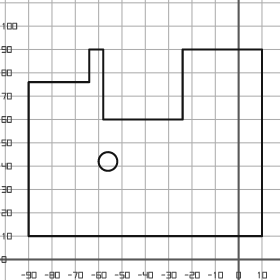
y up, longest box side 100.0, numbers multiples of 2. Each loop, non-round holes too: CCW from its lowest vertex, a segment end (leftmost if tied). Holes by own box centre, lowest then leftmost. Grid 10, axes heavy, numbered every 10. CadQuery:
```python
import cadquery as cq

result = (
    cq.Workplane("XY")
    .moveTo(-90.0, 10.0)
    .lineTo(10.0, 10.0)
    .lineTo(10.0, 90.0)
    .lineTo(-24.0, 90.0)
    .lineTo(-24.0, 60.0)
    .lineTo(-58.0, 60.0)
    .lineTo(-58.0, 90.0)
    .lineTo(-64.0, 90.0)
    .lineTo(-64.0, 76.0)
    .lineTo(-90.0, 76.0)
    .close()
    .moveTo(-56.0, 42.0)
    .circle(4.0)
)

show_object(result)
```